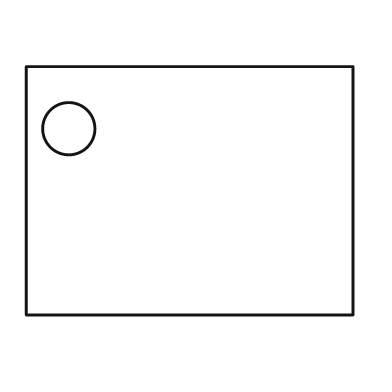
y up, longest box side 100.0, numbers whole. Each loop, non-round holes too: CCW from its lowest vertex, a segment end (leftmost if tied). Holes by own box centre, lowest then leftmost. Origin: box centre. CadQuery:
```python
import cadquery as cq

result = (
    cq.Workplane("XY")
    .moveTo(-50.0, -38.0)
    .lineTo(50.0, -38.0)
    .lineTo(50.0, 38.0)
    .lineTo(-50.0, 38.0)
    .close()
    .moveTo(-37.0, 19.0)
    .circle(8.0)
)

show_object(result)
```